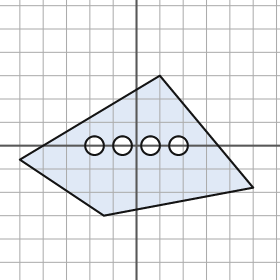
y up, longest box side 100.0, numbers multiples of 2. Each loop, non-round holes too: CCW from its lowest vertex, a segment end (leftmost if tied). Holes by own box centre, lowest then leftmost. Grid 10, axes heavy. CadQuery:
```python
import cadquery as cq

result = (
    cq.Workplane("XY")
    .moveTo(-14.0, -30.0)
    .lineTo(50.0, -18.0)
    .lineTo(10.0, 30.0)
    .lineTo(-50.0, -6.0)
    .close()
    .moveTo(-18.0, 0.0)
    .circle(4.0)
    .moveTo(-6.0, 0.0)
    .circle(4.0)
    .moveTo(6.0, 0.0)
    .circle(4.0)
    .moveTo(18.0, 0.0)
    .circle(4.0)
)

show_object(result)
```